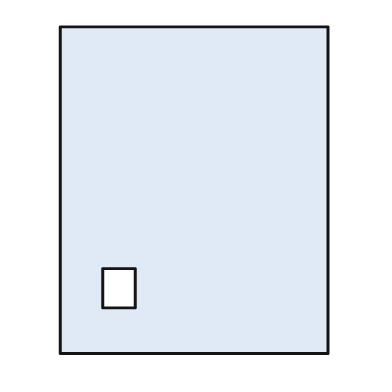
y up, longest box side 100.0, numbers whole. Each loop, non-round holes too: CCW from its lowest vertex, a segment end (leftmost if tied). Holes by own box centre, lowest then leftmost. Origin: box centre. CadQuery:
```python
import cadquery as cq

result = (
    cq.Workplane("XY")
    .moveTo(-41.0, -50.0)
    .lineTo(41.0, -50.0)
    .lineTo(41.0, 50.0)
    .lineTo(-41.0, 50.0)
    .close()
    .moveTo(-28.0, -36.0)
    .lineTo(-18.0, -36.0)
    .lineTo(-18.0, -24.0)
    .lineTo(-28.0, -24.0)
    .close()
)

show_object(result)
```